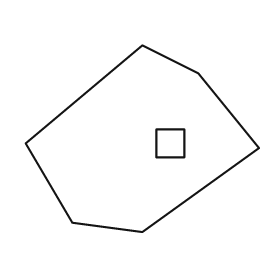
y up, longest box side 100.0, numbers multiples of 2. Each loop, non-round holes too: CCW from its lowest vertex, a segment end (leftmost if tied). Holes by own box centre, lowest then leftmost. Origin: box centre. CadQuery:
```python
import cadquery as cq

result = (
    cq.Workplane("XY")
    .moveTo(0.0, -40.0)
    .lineTo(50.0, -4.0)
    .lineTo(24.0, 28.0)
    .lineTo(0.0, 40.0)
    .lineTo(-50.0, -2.0)
    .lineTo(-30.0, -36.0)
    .close()
    .moveTo(6.0, -8.0)
    .lineTo(18.0, -8.0)
    .lineTo(18.0, 4.0)
    .lineTo(6.0, 4.0)
    .close()
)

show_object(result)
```